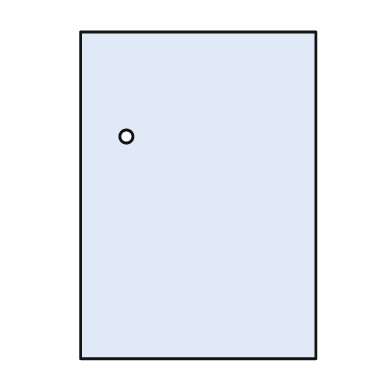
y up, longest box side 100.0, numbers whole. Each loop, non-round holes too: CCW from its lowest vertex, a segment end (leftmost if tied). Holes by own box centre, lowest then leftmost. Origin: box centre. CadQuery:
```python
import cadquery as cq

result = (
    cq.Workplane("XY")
    .moveTo(-36.0, -50.0)
    .lineTo(36.0, -50.0)
    .lineTo(36.0, 50.0)
    .lineTo(-36.0, 50.0)
    .close()
    .moveTo(-22.0, 18.0)
    .circle(2.0)
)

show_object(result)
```